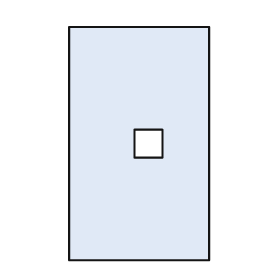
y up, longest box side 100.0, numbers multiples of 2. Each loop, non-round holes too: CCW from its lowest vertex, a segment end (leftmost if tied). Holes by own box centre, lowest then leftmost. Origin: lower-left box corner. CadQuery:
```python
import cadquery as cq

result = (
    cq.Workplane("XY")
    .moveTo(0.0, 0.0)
    .lineTo(60.0, 0.0)
    .lineTo(60.0, 100.0)
    .lineTo(0.0, 100.0)
    .close()
    .moveTo(28.0, 44.0)
    .lineTo(40.0, 44.0)
    .lineTo(40.0, 56.0)
    .lineTo(28.0, 56.0)
    .close()
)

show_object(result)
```